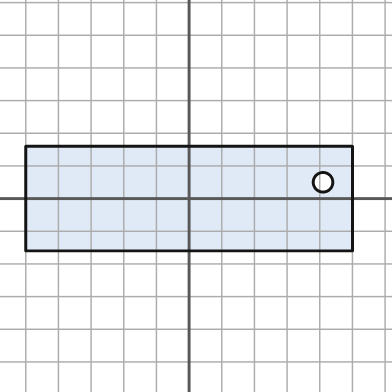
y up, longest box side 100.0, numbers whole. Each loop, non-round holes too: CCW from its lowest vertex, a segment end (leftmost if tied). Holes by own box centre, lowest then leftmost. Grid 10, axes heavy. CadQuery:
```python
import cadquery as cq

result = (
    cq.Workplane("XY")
    .moveTo(-50.0, -16.0)
    .lineTo(50.0, -16.0)
    .lineTo(50.0, 16.0)
    .lineTo(-50.0, 16.0)
    .close()
    .moveTo(41.0, 5.0)
    .circle(3.0)
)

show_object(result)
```